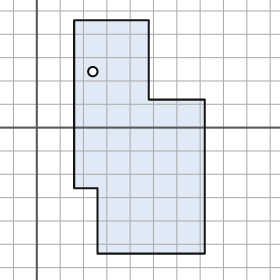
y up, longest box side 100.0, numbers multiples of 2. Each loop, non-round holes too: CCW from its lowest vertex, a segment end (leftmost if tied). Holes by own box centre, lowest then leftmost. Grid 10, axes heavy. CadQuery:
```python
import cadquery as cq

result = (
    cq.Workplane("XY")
    .moveTo(26.0, -54.0)
    .lineTo(72.0, -54.0)
    .lineTo(72.0, 12.0)
    .lineTo(48.0, 12.0)
    .lineTo(48.0, 46.0)
    .lineTo(16.0, 46.0)
    .lineTo(16.0, -26.0)
    .lineTo(26.0, -26.0)
    .close()
    .moveTo(24.0, 24.0)
    .circle(2.0)
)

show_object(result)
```